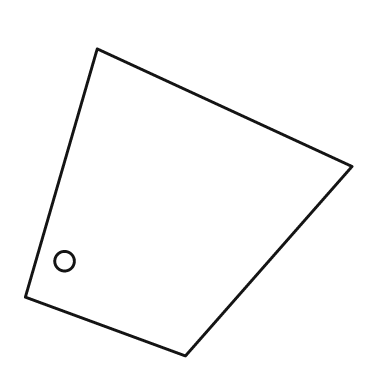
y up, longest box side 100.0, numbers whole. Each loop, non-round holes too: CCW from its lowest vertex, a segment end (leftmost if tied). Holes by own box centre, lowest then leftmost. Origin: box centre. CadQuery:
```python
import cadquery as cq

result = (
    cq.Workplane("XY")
    .moveTo(-1.0, -47.0)
    .lineTo(50.0, 11.0)
    .lineTo(-28.0, 47.0)
    .lineTo(-50.0, -29.0)
    .close()
    .moveTo(-38.0, -18.0)
    .circle(3.0)
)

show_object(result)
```